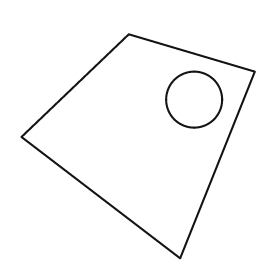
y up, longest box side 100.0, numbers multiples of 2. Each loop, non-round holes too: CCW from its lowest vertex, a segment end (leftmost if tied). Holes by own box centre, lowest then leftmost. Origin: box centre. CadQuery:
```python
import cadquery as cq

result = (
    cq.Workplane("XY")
    .moveTo(18.0, -48.0)
    .lineTo(50.0, 32.0)
    .lineTo(-4.0, 48.0)
    .lineTo(-50.0, 4.0)
    .close()
    .moveTo(24.0, 20.0)
    .circle(12.0)
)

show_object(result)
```